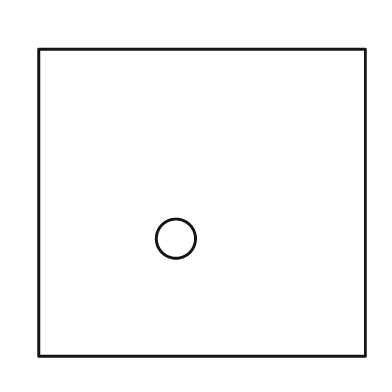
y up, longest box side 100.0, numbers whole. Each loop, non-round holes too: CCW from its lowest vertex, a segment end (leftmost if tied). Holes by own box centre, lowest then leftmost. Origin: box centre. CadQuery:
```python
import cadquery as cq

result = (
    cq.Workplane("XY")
    .moveTo(-50.0, -47.0)
    .lineTo(50.0, -47.0)
    .lineTo(50.0, 47.0)
    .lineTo(-50.0, 47.0)
    .close()
    .moveTo(-8.0, -11.0)
    .circle(6.0)
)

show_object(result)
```